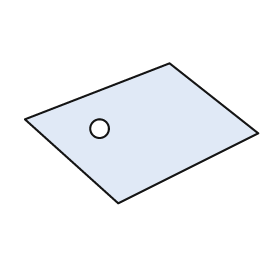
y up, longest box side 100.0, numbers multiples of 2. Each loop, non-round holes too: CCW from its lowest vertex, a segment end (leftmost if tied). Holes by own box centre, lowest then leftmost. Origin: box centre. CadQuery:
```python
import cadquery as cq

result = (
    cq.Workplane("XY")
    .moveTo(-10.0, -30.0)
    .lineTo(50.0, 0.0)
    .lineTo(12.0, 30.0)
    .lineTo(-50.0, 6.0)
    .close()
    .moveTo(-18.0, 2.0)
    .circle(4.0)
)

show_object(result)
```